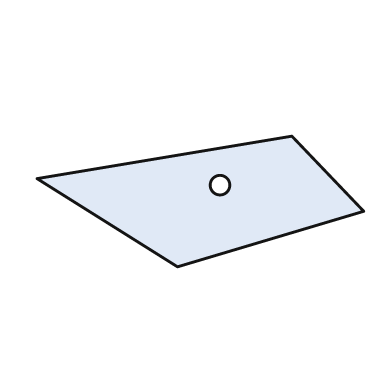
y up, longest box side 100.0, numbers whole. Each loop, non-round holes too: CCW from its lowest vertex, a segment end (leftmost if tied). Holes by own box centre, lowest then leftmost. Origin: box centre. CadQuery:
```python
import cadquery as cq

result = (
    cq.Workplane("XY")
    .moveTo(-7.0, -20.0)
    .lineTo(50.0, -3.0)
    .lineTo(28.0, 20.0)
    .lineTo(-50.0, 7.0)
    .close()
    .moveTo(6.0, 5.0)
    .circle(3.0)
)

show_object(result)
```